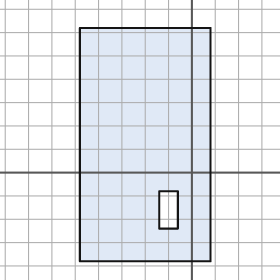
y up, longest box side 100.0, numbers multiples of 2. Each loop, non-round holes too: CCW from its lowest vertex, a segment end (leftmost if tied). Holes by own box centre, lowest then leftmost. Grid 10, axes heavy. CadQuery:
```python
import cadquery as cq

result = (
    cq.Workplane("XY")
    .moveTo(-48.0, -38.0)
    .lineTo(8.0, -38.0)
    .lineTo(8.0, 62.0)
    .lineTo(-48.0, 62.0)
    .close()
    .moveTo(-14.0, -24.0)
    .lineTo(-6.0, -24.0)
    .lineTo(-6.0, -8.0)
    .lineTo(-14.0, -8.0)
    .close()
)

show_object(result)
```